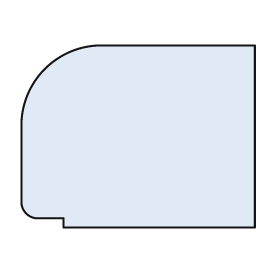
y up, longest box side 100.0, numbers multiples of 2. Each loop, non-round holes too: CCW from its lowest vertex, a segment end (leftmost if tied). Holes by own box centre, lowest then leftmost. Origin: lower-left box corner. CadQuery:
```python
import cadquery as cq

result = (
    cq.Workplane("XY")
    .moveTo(18.0, 0.0)
    .lineTo(100.0, 0.0)
    .lineTo(100.0, 78.0)
    .lineTo(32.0, 78.0)
    .threePointArc((10.0, 68.0), (0.0, 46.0))
    .lineTo(0.0, 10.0)
    .threePointArc((2.0, 6.0), (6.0, 4.0))
    .lineTo(18.0, 4.0)
    .close()
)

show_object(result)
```